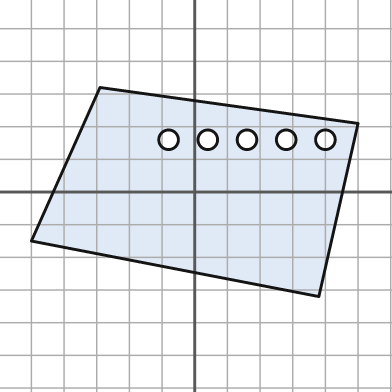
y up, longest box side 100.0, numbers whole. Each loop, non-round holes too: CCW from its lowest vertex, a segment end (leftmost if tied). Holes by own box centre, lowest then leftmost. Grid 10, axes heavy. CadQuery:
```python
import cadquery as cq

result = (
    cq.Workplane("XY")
    .moveTo(38.0, -32.0)
    .lineTo(50.0, 21.0)
    .lineTo(-29.0, 32.0)
    .lineTo(-50.0, -15.0)
    .close()
    .moveTo(-8.0, 16.0)
    .circle(3.0)
    .moveTo(4.0, 16.0)
    .circle(3.0)
    .moveTo(16.0, 16.0)
    .circle(3.0)
    .moveTo(28.0, 16.0)
    .circle(3.0)
    .moveTo(40.0, 16.0)
    .circle(3.0)
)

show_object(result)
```